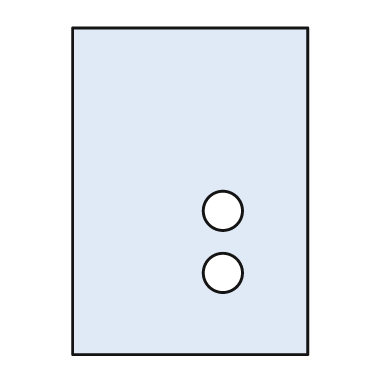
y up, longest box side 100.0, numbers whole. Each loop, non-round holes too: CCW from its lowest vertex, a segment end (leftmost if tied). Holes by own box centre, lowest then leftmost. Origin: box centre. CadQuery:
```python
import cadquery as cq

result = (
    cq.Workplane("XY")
    .moveTo(-36.0, -50.0)
    .lineTo(36.0, -50.0)
    .lineTo(36.0, 50.0)
    .lineTo(-36.0, 50.0)
    .close()
    .moveTo(10.0, -25.0)
    .circle(6.0)
    .moveTo(10.0, -6.0)
    .circle(6.0)
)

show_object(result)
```